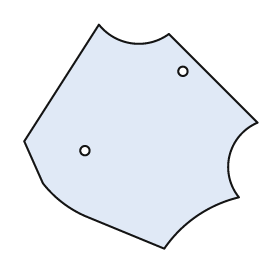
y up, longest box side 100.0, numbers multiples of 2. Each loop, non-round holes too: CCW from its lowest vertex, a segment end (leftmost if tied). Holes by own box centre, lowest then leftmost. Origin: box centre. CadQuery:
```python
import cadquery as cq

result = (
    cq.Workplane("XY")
    .moveTo(10.0, -48.0)
    .threePointArc((24.0, -34.0), (42.0, -26.0))
    .threePointArc((38.0, -8.0), (50.0, 6.0))
    .lineTo(12.0, 44.0)
    .threePointArc((-4.0, 40.0), (-18.0, 48.0))
    .lineTo(-50.0, -2.0)
    .lineTo(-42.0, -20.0)
    .threePointArc((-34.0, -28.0), (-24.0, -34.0))
    .close()
    .moveTo(-24.0, -6.0)
    .circle(2.0)
    .moveTo(18.0, 28.0)
    .circle(2.0)
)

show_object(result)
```